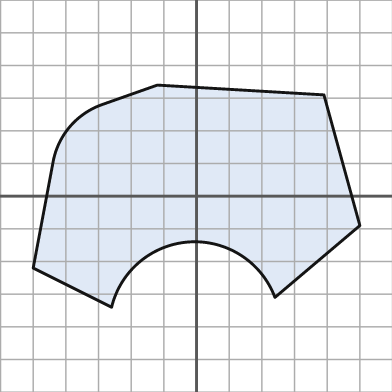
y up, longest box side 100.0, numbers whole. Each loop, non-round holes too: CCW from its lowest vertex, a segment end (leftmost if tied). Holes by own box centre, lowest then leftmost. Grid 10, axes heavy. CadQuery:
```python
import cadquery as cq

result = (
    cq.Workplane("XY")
    .moveTo(-26.0, -34.0)
    .threePointArc((-2.0, -14.0), (24.0, -31.0))
    .lineTo(50.0, -9.0)
    .lineTo(39.0, 31.0)
    .lineTo(-12.0, 34.0)
    .lineTo(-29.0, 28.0)
    .threePointArc((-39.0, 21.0), (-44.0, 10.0))
    .lineTo(-50.0, -22.0)
    .close()
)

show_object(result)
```